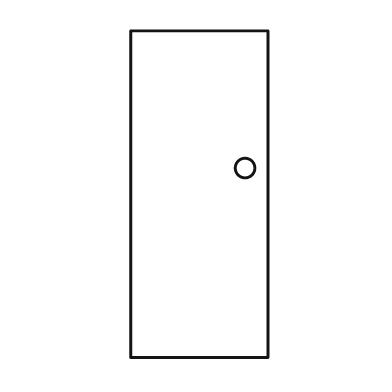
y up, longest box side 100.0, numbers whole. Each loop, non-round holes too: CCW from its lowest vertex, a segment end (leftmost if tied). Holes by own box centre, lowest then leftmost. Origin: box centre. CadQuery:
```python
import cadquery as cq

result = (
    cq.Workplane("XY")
    .moveTo(-21.0, -50.0)
    .lineTo(21.0, -50.0)
    .lineTo(21.0, 50.0)
    .lineTo(-21.0, 50.0)
    .close()
    .moveTo(14.0, 8.0)
    .circle(3.0)
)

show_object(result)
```